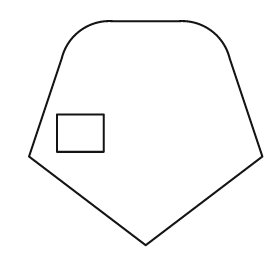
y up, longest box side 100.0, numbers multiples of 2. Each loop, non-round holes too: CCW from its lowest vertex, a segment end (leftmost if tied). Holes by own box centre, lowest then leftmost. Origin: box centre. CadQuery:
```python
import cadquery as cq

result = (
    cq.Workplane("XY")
    .moveTo(0.0, -48.0)
    .lineTo(50.0, -10.0)
    .lineTo(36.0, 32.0)
    .threePointArc((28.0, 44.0), (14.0, 48.0))
    .lineTo(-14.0, 48.0)
    .threePointArc((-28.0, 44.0), (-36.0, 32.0))
    .lineTo(-50.0, -10.0)
    .close()
    .moveTo(-38.0, -8.0)
    .lineTo(-18.0, -8.0)
    .lineTo(-18.0, 8.0)
    .lineTo(-38.0, 8.0)
    .close()
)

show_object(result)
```